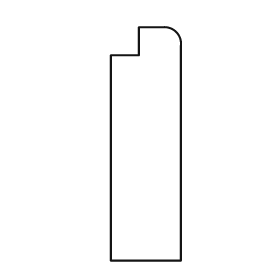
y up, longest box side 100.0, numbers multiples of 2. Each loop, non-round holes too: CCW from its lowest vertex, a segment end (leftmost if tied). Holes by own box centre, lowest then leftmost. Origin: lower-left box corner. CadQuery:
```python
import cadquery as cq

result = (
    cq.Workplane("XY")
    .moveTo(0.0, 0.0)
    .lineTo(30.0, 0.0)
    .lineTo(30.0, 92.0)
    .threePointArc((28.0, 98.0), (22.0, 100.0))
    .lineTo(12.0, 100.0)
    .lineTo(12.0, 88.0)
    .lineTo(0.0, 88.0)
    .close()
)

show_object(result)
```